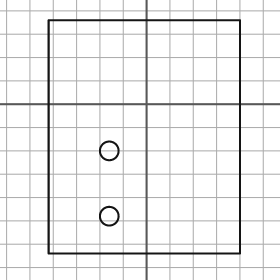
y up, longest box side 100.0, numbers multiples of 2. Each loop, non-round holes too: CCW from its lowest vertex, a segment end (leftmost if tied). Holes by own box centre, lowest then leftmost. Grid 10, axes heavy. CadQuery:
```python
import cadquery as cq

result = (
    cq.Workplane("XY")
    .moveTo(-42.0, -64.0)
    .lineTo(40.0, -64.0)
    .lineTo(40.0, 36.0)
    .lineTo(-42.0, 36.0)
    .close()
    .moveTo(-16.0, -48.0)
    .circle(4.0)
    .moveTo(-16.0, -20.0)
    .circle(4.0)
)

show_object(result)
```